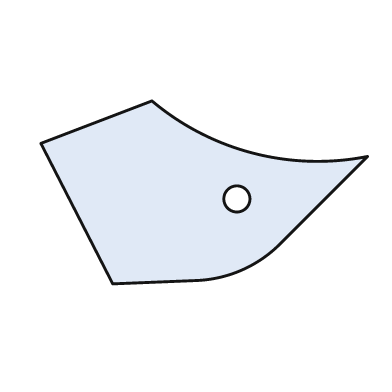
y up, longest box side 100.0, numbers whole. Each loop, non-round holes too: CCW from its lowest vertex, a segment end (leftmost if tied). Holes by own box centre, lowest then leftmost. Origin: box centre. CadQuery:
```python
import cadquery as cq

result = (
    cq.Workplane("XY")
    .moveTo(-28.0, -28.0)
    .lineTo(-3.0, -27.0)
    .threePointArc((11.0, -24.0), (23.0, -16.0))
    .lineTo(50.0, 11.0)
    .threePointArc((15.0, 12.0), (-16.0, 28.0))
    .lineTo(-50.0, 15.0)
    .close()
    .moveTo(10.0, -2.0)
    .circle(4.0)
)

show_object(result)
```